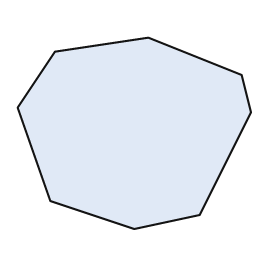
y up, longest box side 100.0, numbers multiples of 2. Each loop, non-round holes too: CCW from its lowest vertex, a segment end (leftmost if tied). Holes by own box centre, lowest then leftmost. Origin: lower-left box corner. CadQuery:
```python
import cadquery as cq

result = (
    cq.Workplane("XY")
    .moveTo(50.0, 0.0)
    .lineTo(78.0, 6.0)
    .lineTo(100.0, 50.0)
    .lineTo(96.0, 66.0)
    .lineTo(56.0, 82.0)
    .lineTo(16.0, 76.0)
    .lineTo(0.0, 52.0)
    .lineTo(14.0, 12.0)
    .close()
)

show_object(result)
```